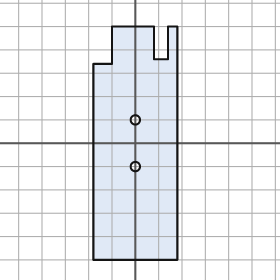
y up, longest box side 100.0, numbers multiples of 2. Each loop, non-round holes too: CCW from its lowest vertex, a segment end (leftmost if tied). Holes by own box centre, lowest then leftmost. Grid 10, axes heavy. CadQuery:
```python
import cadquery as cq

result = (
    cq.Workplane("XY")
    .moveTo(-18.0, -50.0)
    .lineTo(18.0, -50.0)
    .lineTo(18.0, 50.0)
    .lineTo(14.0, 50.0)
    .lineTo(14.0, 36.0)
    .lineTo(8.0, 36.0)
    .lineTo(8.0, 50.0)
    .lineTo(-10.0, 50.0)
    .lineTo(-10.0, 34.0)
    .lineTo(-18.0, 34.0)
    .close()
    .moveTo(0.0, -10.0)
    .circle(2.0)
    .moveTo(0.0, 10.0)
    .circle(2.0)
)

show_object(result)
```